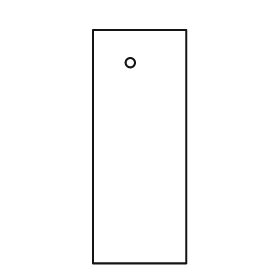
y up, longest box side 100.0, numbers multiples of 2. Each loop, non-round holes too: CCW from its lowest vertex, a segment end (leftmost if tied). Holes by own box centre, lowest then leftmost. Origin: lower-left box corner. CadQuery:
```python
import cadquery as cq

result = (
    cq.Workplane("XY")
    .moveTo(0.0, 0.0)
    .lineTo(40.0, 0.0)
    .lineTo(40.0, 100.0)
    .lineTo(0.0, 100.0)
    .close()
    .moveTo(16.0, 86.0)
    .circle(2.0)
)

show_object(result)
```